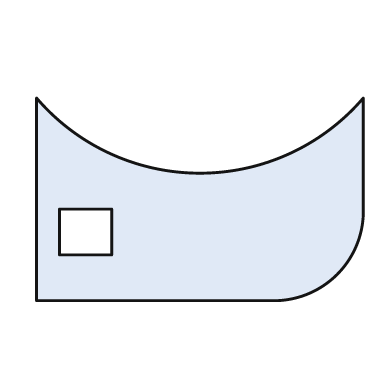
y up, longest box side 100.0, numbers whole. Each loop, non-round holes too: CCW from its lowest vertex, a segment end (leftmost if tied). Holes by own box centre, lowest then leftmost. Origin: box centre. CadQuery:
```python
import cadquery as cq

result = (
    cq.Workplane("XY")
    .moveTo(-50.0, -31.0)
    .lineTo(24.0, -31.0)
    .threePointArc((42.0, -23.0), (50.0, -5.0))
    .lineTo(50.0, 31.0)
    .threePointArc((0.0, 8.0), (-50.0, 31.0))
    .close()
    .moveTo(-43.0, -17.0)
    .lineTo(-27.0, -17.0)
    .lineTo(-27.0, -3.0)
    .lineTo(-43.0, -3.0)
    .close()
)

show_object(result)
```